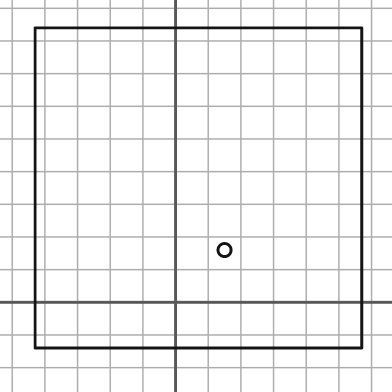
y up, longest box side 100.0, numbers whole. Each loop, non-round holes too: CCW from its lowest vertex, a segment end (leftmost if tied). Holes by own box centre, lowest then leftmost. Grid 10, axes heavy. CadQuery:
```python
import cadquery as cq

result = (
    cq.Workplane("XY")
    .moveTo(-43.0, -14.0)
    .lineTo(57.0, -14.0)
    .lineTo(57.0, 84.0)
    .lineTo(-43.0, 84.0)
    .close()
    .moveTo(15.0, 16.0)
    .circle(2.0)
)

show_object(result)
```